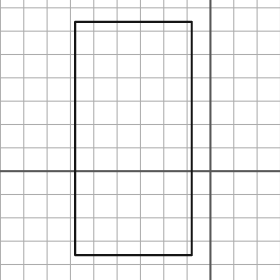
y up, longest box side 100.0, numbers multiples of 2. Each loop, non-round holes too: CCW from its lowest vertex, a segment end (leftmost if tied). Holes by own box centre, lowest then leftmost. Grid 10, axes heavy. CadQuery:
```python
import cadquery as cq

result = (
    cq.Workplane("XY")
    .moveTo(-58.0, -36.0)
    .lineTo(-8.0, -36.0)
    .lineTo(-8.0, 64.0)
    .lineTo(-58.0, 64.0)
    .close()
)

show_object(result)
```